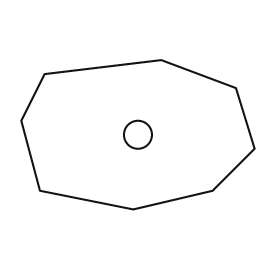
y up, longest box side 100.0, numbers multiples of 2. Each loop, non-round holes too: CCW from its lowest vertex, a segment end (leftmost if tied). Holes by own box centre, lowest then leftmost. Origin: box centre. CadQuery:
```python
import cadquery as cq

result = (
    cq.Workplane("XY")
    .moveTo(-2.0, -32.0)
    .lineTo(32.0, -24.0)
    .lineTo(50.0, -6.0)
    .lineTo(42.0, 20.0)
    .lineTo(10.0, 32.0)
    .lineTo(-40.0, 26.0)
    .lineTo(-50.0, 6.0)
    .lineTo(-42.0, -24.0)
    .close()
    .moveTo(0.0, 0.0)
    .circle(6.0)
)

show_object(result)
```